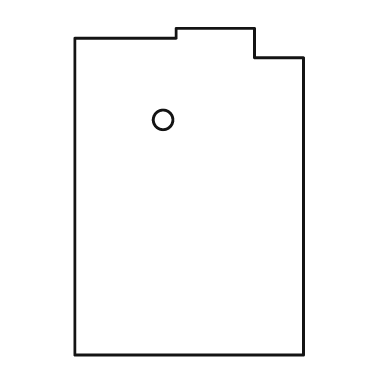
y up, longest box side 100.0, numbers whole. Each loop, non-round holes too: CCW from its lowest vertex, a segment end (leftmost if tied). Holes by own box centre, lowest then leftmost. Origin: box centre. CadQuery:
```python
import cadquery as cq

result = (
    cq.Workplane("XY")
    .moveTo(-35.0, -50.0)
    .lineTo(35.0, -50.0)
    .lineTo(35.0, 41.0)
    .lineTo(20.0, 41.0)
    .lineTo(20.0, 50.0)
    .lineTo(-4.0, 50.0)
    .lineTo(-4.0, 47.0)
    .lineTo(-35.0, 47.0)
    .close()
    .moveTo(-8.0, 22.0)
    .circle(3.0)
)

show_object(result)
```